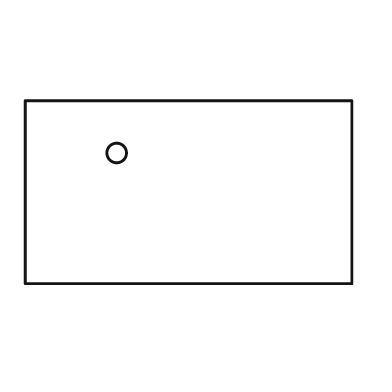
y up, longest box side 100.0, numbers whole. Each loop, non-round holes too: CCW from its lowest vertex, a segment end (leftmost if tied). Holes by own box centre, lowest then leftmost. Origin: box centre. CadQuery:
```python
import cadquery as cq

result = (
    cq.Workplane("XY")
    .moveTo(-50.0, -28.0)
    .lineTo(50.0, -28.0)
    .lineTo(50.0, 28.0)
    .lineTo(-50.0, 28.0)
    .close()
    .moveTo(-22.0, 12.0)
    .circle(3.0)
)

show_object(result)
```